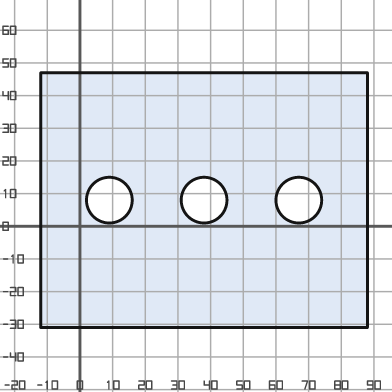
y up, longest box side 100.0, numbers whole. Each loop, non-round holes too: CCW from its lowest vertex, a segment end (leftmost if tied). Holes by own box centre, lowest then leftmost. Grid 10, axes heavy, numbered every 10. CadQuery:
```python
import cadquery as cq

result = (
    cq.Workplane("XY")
    .moveTo(-12.0, -31.0)
    .lineTo(88.0, -31.0)
    .lineTo(88.0, 47.0)
    .lineTo(-12.0, 47.0)
    .close()
    .moveTo(9.0, 8.0)
    .circle(7.0)
    .moveTo(38.0, 8.0)
    .circle(7.0)
    .moveTo(67.0, 8.0)
    .circle(7.0)
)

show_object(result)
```